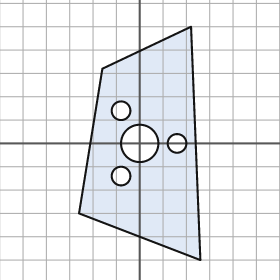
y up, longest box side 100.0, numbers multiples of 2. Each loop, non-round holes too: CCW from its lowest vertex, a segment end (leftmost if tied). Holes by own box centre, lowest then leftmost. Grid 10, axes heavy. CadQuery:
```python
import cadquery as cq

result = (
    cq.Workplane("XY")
    .moveTo(26.0, -50.0)
    .lineTo(22.0, 50.0)
    .lineTo(-16.0, 32.0)
    .lineTo(-26.0, -30.0)
    .close()
    .moveTo(-8.0, -14.0)
    .circle(4.0)
    .moveTo(0.0, 0.0)
    .circle(8.0)
    .moveTo(16.0, 0.0)
    .circle(4.0)
    .moveTo(-8.0, 14.0)
    .circle(4.0)
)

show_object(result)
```